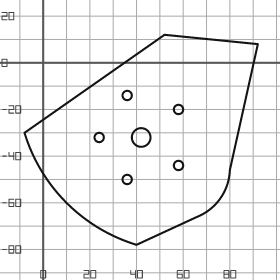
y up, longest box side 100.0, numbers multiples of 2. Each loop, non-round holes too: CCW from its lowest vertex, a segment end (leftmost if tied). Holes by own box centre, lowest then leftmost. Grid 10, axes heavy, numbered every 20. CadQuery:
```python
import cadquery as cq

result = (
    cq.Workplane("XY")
    .moveTo(40.0, -78.0)
    .lineTo(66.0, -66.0)
    .threePointArc((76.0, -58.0), (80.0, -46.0))
    .lineTo(92.0, 8.0)
    .lineTo(52.0, 12.0)
    .lineTo(-8.0, -30.0)
    .threePointArc((10.0, -60.0), (40.0, -78.0))
    .close()
    .moveTo(36.0, -50.0)
    .circle(2.0)
    .moveTo(58.0, -44.0)
    .circle(2.0)
    .moveTo(24.0, -32.0)
    .circle(2.0)
    .moveTo(42.0, -32.0)
    .circle(4.0)
    .moveTo(58.0, -20.0)
    .circle(2.0)
    .moveTo(36.0, -14.0)
    .circle(2.0)
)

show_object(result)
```